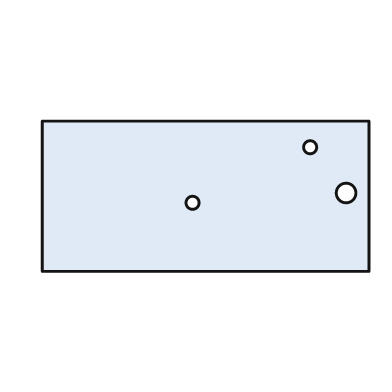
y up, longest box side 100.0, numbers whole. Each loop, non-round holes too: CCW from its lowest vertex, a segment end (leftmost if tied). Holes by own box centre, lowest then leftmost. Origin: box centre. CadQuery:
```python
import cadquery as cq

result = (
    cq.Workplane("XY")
    .moveTo(-50.0, -23.0)
    .lineTo(50.0, -23.0)
    .lineTo(50.0, 23.0)
    .lineTo(-50.0, 23.0)
    .close()
    .moveTo(-4.0, -2.0)
    .circle(2.0)
    .moveTo(43.0, 1.0)
    .circle(3.0)
    .moveTo(32.0, 15.0)
    .circle(2.0)
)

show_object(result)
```